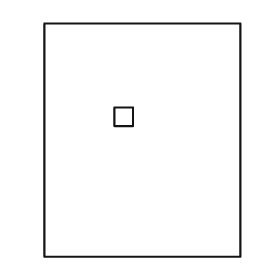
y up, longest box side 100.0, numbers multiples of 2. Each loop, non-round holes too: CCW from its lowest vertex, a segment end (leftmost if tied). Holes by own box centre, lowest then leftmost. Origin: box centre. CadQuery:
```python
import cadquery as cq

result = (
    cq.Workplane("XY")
    .moveTo(-42.0, -50.0)
    .lineTo(42.0, -50.0)
    .lineTo(42.0, 50.0)
    .lineTo(-42.0, 50.0)
    .close()
    .moveTo(-12.0, 6.0)
    .lineTo(-4.0, 6.0)
    .lineTo(-4.0, 14.0)
    .lineTo(-12.0, 14.0)
    .close()
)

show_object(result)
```